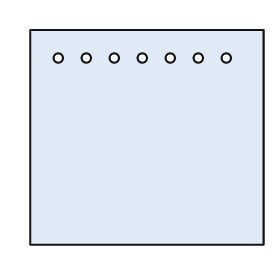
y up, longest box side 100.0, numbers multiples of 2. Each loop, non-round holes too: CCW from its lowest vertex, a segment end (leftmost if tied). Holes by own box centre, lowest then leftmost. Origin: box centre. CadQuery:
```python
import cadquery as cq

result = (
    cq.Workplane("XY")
    .moveTo(-50.0, -46.0)
    .lineTo(50.0, -46.0)
    .lineTo(50.0, 46.0)
    .lineTo(-50.0, 46.0)
    .close()
    .moveTo(-38.0, 34.0)
    .circle(2.0)
    .moveTo(-26.0, 34.0)
    .circle(2.0)
    .moveTo(-14.0, 34.0)
    .circle(2.0)
    .moveTo(-2.0, 34.0)
    .circle(2.0)
    .moveTo(10.0, 34.0)
    .circle(2.0)
    .moveTo(22.0, 34.0)
    .circle(2.0)
    .moveTo(34.0, 34.0)
    .circle(2.0)
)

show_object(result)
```